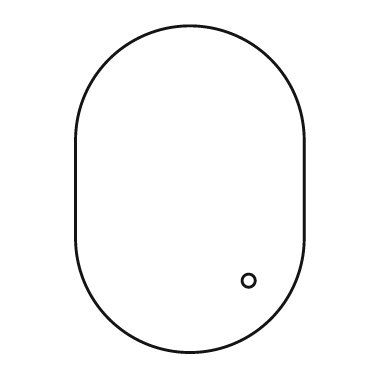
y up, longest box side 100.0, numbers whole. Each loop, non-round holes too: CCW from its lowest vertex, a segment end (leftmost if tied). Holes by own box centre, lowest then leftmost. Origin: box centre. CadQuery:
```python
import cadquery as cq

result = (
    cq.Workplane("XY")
    .moveTo(-35.0, -15.0)
    .threePointArc((0.0, -50.0), (35.0, -15.0))
    .lineTo(35.0, 15.0)
    .threePointArc((0.0, 50.0), (-35.0, 15.0))
    .close()
    .moveTo(18.0, -28.0)
    .circle(2.0)
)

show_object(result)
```